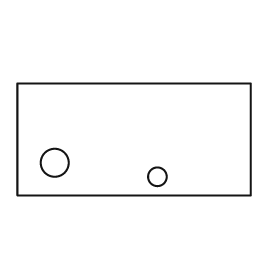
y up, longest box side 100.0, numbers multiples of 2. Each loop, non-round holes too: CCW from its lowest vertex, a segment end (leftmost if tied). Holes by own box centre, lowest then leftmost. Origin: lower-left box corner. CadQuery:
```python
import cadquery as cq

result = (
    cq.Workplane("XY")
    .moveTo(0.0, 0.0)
    .lineTo(100.0, 0.0)
    .lineTo(100.0, 48.0)
    .lineTo(0.0, 48.0)
    .close()
    .moveTo(60.0, 8.0)
    .circle(4.0)
    .moveTo(16.0, 14.0)
    .circle(6.0)
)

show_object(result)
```